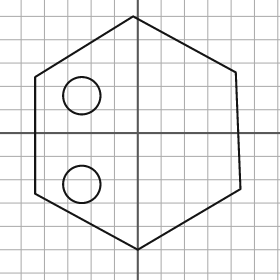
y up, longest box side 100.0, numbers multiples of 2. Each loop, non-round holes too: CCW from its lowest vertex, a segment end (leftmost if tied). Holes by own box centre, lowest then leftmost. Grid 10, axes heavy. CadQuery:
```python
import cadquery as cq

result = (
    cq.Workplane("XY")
    .moveTo(0.0, -50.0)
    .lineTo(44.0, -24.0)
    .lineTo(42.0, 26.0)
    .lineTo(-2.0, 50.0)
    .lineTo(-44.0, 24.0)
    .lineTo(-44.0, -26.0)
    .close()
    .moveTo(-24.0, -22.0)
    .circle(8.0)
    .moveTo(-24.0, 16.0)
    .circle(8.0)
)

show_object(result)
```